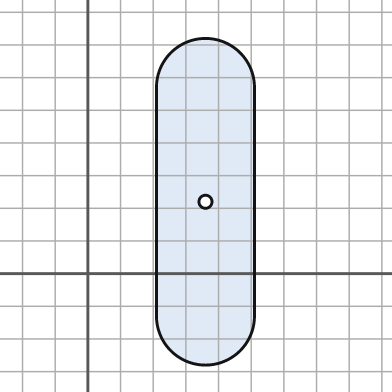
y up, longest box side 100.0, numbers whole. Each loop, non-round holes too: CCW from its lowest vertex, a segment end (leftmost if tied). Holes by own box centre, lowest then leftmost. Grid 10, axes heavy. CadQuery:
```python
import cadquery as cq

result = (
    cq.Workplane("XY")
    .moveTo(21.0, -13.0)
    .threePointArc((36.0, -28.0), (51.0, -13.0))
    .lineTo(51.0, 57.0)
    .threePointArc((36.0, 72.0), (21.0, 57.0))
    .close()
    .moveTo(36.0, 22.0)
    .circle(2.0)
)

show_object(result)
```